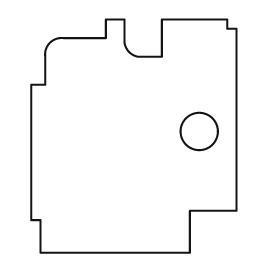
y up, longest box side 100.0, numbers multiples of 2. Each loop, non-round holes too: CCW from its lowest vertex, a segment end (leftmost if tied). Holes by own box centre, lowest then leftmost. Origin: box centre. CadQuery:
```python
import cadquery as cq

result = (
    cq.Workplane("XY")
    .moveTo(-40.0, -50.0)
    .lineTo(24.0, -50.0)
    .lineTo(24.0, -32.0)
    .lineTo(44.0, -32.0)
    .lineTo(44.0, 46.0)
    .lineTo(40.0, 46.0)
    .lineTo(40.0, 50.0)
    .lineTo(12.0, 50.0)
    .lineTo(12.0, 34.0)
    .lineTo(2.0, 34.0)
    .threePointArc((-2.0, 36.0), (-4.0, 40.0))
    .lineTo(-4.0, 50.0)
    .lineTo(-12.0, 50.0)
    .lineTo(-12.0, 42.0)
    .lineTo(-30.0, 42.0)
    .threePointArc((-36.0, 40.0), (-38.0, 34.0))
    .lineTo(-38.0, 22.0)
    .lineTo(-44.0, 22.0)
    .lineTo(-44.0, -36.0)
    .lineTo(-40.0, -36.0)
    .close()
    .moveTo(28.0, 2.0)
    .circle(8.0)
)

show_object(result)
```